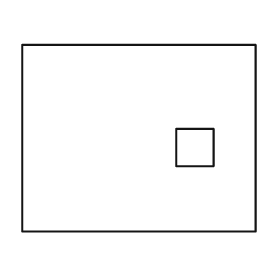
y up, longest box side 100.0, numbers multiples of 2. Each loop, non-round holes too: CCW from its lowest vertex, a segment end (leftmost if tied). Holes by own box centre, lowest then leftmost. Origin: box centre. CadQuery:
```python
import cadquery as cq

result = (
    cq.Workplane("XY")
    .moveTo(-50.0, -40.0)
    .lineTo(50.0, -40.0)
    .lineTo(50.0, 40.0)
    .lineTo(-50.0, 40.0)
    .close()
    .moveTo(16.0, -12.0)
    .lineTo(32.0, -12.0)
    .lineTo(32.0, 4.0)
    .lineTo(16.0, 4.0)
    .close()
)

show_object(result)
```